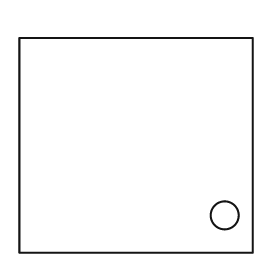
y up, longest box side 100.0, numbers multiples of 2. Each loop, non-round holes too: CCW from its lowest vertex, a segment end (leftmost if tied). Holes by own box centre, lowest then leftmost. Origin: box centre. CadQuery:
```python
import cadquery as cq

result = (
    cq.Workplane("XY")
    .moveTo(-50.0, -46.0)
    .lineTo(50.0, -46.0)
    .lineTo(50.0, 46.0)
    .lineTo(-50.0, 46.0)
    .close()
    .moveTo(38.0, -30.0)
    .circle(6.0)
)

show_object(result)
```